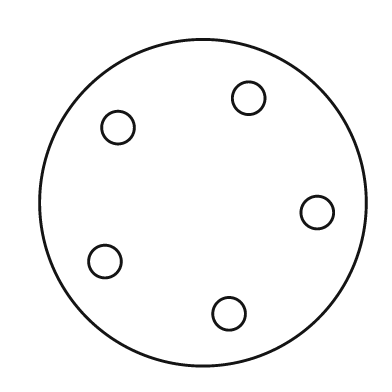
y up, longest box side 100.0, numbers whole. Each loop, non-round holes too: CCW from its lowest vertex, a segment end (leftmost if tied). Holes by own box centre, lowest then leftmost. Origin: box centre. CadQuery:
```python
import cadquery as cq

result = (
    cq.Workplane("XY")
    .moveTo(0.0, 0.0)
    .circle(50.0)
    .moveTo(8.0, -34.0)
    .circle(5.0)
    .moveTo(-30.0, -18.0)
    .circle(5.0)
    .moveTo(35.0, -3.0)
    .circle(5.0)
    .moveTo(-26.0, 23.0)
    .circle(5.0)
    .moveTo(14.0, 32.0)
    .circle(5.0)
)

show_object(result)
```